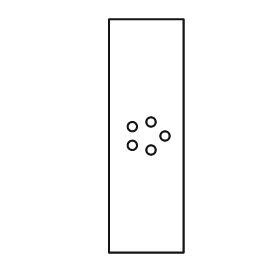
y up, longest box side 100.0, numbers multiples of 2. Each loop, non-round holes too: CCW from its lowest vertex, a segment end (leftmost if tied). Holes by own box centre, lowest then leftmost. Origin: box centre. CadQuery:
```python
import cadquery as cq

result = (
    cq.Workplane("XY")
    .moveTo(-16.0, -50.0)
    .lineTo(16.0, -50.0)
    .lineTo(16.0, 50.0)
    .lineTo(-16.0, 50.0)
    .close()
    .moveTo(2.0, -6.0)
    .circle(2.0)
    .moveTo(-6.0, -4.0)
    .circle(2.0)
    .moveTo(8.0, 0.0)
    .circle(2.0)
    .moveTo(-6.0, 4.0)
    .circle(2.0)
    .moveTo(2.0, 6.0)
    .circle(2.0)
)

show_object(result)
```